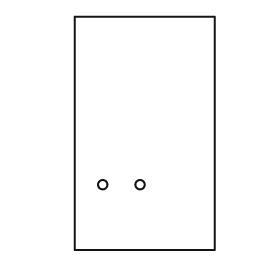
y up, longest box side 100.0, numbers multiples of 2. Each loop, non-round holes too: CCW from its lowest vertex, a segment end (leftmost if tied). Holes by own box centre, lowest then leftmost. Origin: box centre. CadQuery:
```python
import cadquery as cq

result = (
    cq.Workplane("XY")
    .moveTo(-30.0, -50.0)
    .lineTo(30.0, -50.0)
    .lineTo(30.0, 50.0)
    .lineTo(-30.0, 50.0)
    .close()
    .moveTo(-18.0, -22.0)
    .circle(2.0)
    .moveTo(-2.0, -22.0)
    .circle(2.0)
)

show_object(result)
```